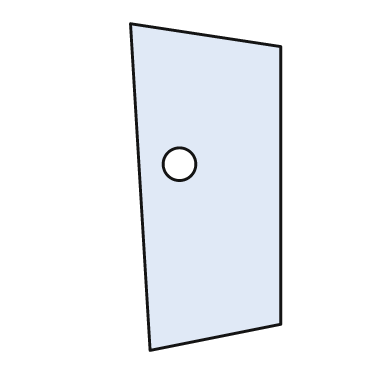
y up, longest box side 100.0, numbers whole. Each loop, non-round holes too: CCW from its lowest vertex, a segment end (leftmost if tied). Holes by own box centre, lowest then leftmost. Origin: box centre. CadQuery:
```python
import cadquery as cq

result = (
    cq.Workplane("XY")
    .moveTo(-17.0, -50.0)
    .lineTo(23.0, -42.0)
    .lineTo(23.0, 43.0)
    .lineTo(-23.0, 50.0)
    .close()
    .moveTo(-8.0, 7.0)
    .circle(5.0)
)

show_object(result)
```